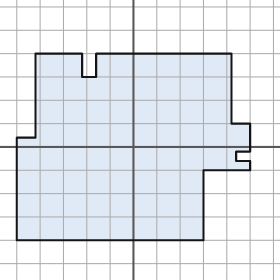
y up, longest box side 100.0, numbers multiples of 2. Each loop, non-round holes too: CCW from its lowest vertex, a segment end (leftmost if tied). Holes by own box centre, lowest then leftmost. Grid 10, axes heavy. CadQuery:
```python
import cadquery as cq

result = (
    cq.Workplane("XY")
    .moveTo(-50.0, -40.0)
    .lineTo(30.0, -40.0)
    .lineTo(30.0, -10.0)
    .lineTo(50.0, -10.0)
    .lineTo(50.0, -6.0)
    .lineTo(44.0, -6.0)
    .lineTo(44.0, -2.0)
    .lineTo(50.0, -2.0)
    .lineTo(50.0, 10.0)
    .lineTo(42.0, 10.0)
    .lineTo(42.0, 40.0)
    .lineTo(-16.0, 40.0)
    .lineTo(-16.0, 30.0)
    .lineTo(-22.0, 30.0)
    .lineTo(-22.0, 40.0)
    .lineTo(-42.0, 40.0)
    .lineTo(-42.0, 4.0)
    .lineTo(-50.0, 4.0)
    .close()
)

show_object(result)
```